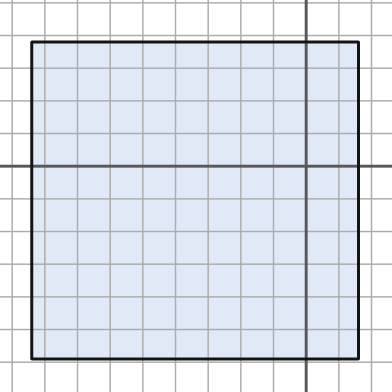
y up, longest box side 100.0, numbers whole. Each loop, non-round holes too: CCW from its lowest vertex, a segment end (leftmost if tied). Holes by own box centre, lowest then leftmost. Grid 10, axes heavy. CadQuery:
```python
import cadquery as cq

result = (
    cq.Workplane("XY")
    .moveTo(-84.0, -59.0)
    .lineTo(16.0, -59.0)
    .lineTo(16.0, 38.0)
    .lineTo(-84.0, 38.0)
    .close()
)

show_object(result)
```